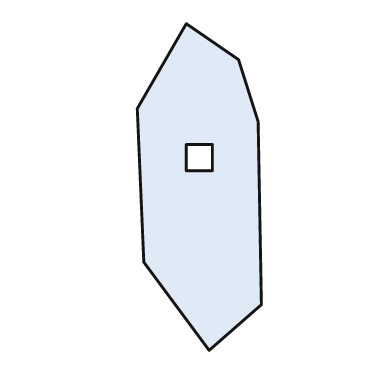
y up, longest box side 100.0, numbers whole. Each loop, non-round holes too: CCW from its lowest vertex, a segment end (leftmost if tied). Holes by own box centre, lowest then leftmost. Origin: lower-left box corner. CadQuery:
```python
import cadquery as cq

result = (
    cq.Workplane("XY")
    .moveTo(22.0, 0.0)
    .lineTo(38.0, 14.0)
    .lineTo(37.0, 70.0)
    .lineTo(31.0, 89.0)
    .lineTo(15.0, 100.0)
    .lineTo(0.0, 74.0)
    .lineTo(2.0, 27.0)
    .close()
    .moveTo(15.0, 55.0)
    .lineTo(23.0, 55.0)
    .lineTo(23.0, 63.0)
    .lineTo(15.0, 63.0)
    .close()
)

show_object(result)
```